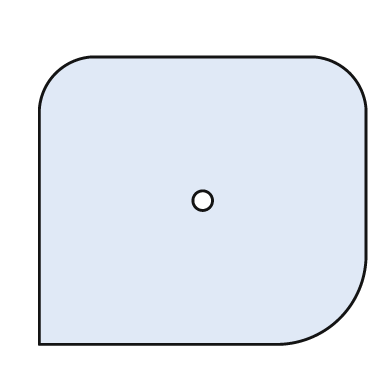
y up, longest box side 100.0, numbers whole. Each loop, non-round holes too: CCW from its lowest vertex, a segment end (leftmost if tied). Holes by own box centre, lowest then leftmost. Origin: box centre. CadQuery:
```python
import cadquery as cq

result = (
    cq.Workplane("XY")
    .moveTo(-50.0, -44.0)
    .lineTo(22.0, -44.0)
    .threePointArc((42.0, -36.0), (50.0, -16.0))
    .lineTo(50.0, 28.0)
    .threePointArc((45.0, 39.0), (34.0, 44.0))
    .lineTo(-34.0, 44.0)
    .threePointArc((-45.0, 39.0), (-50.0, 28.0))
    .close()
    .moveTo(0.0, 0.0)
    .circle(3.0)
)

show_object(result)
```